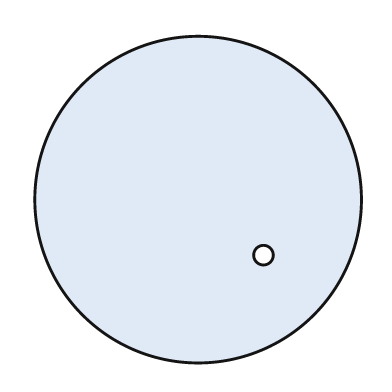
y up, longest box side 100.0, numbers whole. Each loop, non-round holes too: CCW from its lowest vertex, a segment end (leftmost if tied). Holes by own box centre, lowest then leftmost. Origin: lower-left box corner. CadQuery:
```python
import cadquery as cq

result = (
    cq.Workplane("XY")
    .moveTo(50.0, 50.0)
    .circle(50.0)
    .moveTo(70.0, 33.0)
    .circle(3.0)
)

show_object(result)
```